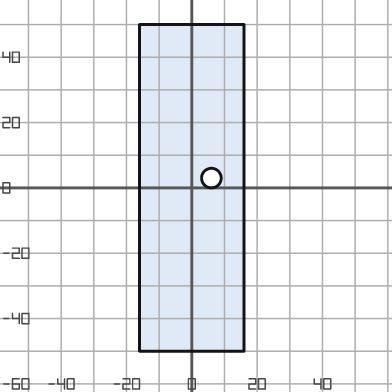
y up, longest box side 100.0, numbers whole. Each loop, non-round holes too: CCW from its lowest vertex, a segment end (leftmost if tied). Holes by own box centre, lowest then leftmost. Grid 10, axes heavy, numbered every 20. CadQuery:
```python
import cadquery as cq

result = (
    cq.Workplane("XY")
    .moveTo(-16.0, -50.0)
    .lineTo(16.0, -50.0)
    .lineTo(16.0, 50.0)
    .lineTo(-16.0, 50.0)
    .close()
    .moveTo(6.0, 3.0)
    .circle(3.0)
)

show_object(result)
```